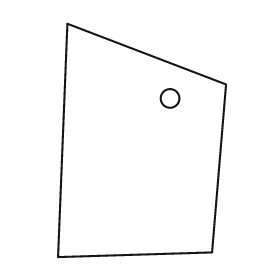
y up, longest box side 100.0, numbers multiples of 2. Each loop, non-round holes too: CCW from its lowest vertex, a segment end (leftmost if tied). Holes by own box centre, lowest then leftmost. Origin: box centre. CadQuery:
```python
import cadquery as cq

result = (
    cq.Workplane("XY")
    .moveTo(-36.0, -50.0)
    .lineTo(30.0, -48.0)
    .lineTo(36.0, 24.0)
    .lineTo(-32.0, 50.0)
    .close()
    .moveTo(12.0, 18.0)
    .circle(4.0)
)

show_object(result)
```